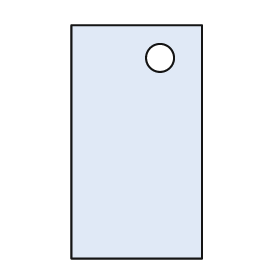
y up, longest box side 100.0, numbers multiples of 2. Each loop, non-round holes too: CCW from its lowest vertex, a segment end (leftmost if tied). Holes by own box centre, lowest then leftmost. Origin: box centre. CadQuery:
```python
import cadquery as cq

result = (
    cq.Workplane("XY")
    .moveTo(-28.0, -50.0)
    .lineTo(28.0, -50.0)
    .lineTo(28.0, 50.0)
    .lineTo(-28.0, 50.0)
    .close()
    .moveTo(10.0, 36.0)
    .circle(6.0)
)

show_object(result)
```